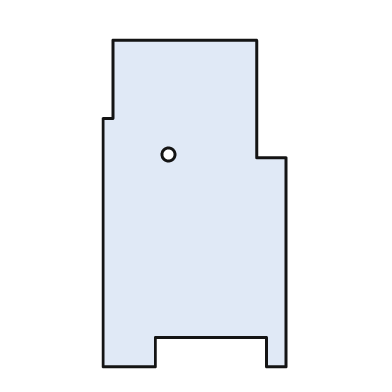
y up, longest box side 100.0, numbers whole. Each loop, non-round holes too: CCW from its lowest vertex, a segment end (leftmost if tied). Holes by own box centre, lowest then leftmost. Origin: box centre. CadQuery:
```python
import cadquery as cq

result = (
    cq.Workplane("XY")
    .moveTo(-28.0, -50.0)
    .lineTo(-12.0, -50.0)
    .lineTo(-12.0, -41.0)
    .lineTo(22.0, -41.0)
    .lineTo(22.0, -50.0)
    .lineTo(28.0, -50.0)
    .lineTo(28.0, 14.0)
    .lineTo(19.0, 14.0)
    .lineTo(19.0, 50.0)
    .lineTo(-25.0, 50.0)
    .lineTo(-25.0, 26.0)
    .lineTo(-28.0, 26.0)
    .close()
    .moveTo(-8.0, 15.0)
    .circle(2.0)
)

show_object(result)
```